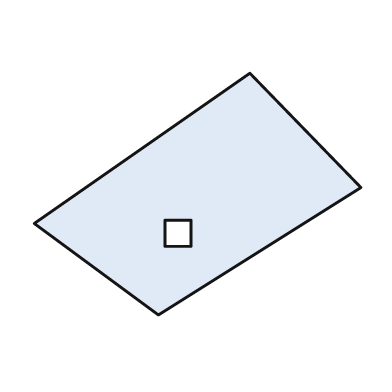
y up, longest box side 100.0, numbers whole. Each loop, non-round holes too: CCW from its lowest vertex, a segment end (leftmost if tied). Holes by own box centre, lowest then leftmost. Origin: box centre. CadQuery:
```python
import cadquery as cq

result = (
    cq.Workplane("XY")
    .moveTo(-12.0, -37.0)
    .lineTo(50.0, 2.0)
    .lineTo(16.0, 37.0)
    .lineTo(-50.0, -9.0)
    .close()
    .moveTo(-10.0, -16.0)
    .lineTo(-2.0, -16.0)
    .lineTo(-2.0, -8.0)
    .lineTo(-10.0, -8.0)
    .close()
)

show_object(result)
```